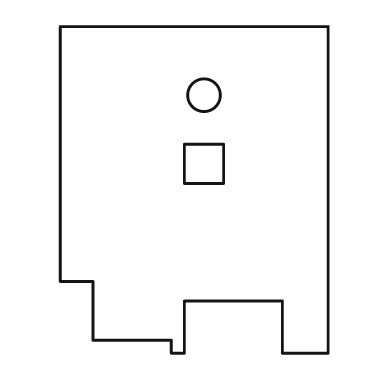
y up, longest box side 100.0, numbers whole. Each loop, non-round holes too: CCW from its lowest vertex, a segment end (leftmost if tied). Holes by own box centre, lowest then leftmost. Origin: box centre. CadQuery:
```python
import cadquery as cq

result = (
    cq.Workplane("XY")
    .moveTo(-7.0, -50.0)
    .lineTo(-3.0, -50.0)
    .lineTo(-3.0, -34.0)
    .lineTo(27.0, -34.0)
    .lineTo(27.0, -50.0)
    .lineTo(41.0, -50.0)
    .lineTo(41.0, 50.0)
    .lineTo(-41.0, 50.0)
    .lineTo(-41.0, -28.0)
    .lineTo(-31.0, -28.0)
    .lineTo(-31.0, -46.0)
    .lineTo(-7.0, -46.0)
    .close()
    .moveTo(-3.0, 2.0)
    .lineTo(9.0, 2.0)
    .lineTo(9.0, 14.0)
    .lineTo(-3.0, 14.0)
    .close()
    .moveTo(3.0, 29.0)
    .circle(5.0)
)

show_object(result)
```